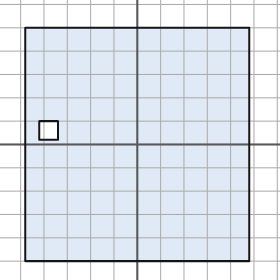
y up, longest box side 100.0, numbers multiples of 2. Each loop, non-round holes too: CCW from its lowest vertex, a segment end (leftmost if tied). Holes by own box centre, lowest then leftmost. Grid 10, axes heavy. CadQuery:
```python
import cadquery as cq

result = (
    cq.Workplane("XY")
    .moveTo(-48.0, -50.0)
    .lineTo(48.0, -50.0)
    .lineTo(48.0, 50.0)
    .lineTo(-48.0, 50.0)
    .close()
    .moveTo(-42.0, 2.0)
    .lineTo(-34.0, 2.0)
    .lineTo(-34.0, 10.0)
    .lineTo(-42.0, 10.0)
    .close()
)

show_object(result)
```